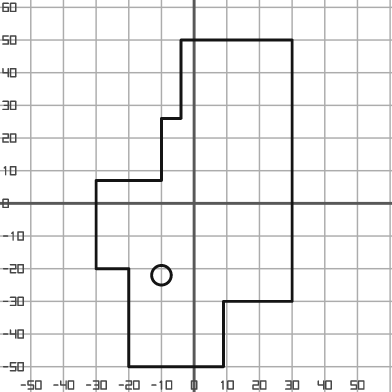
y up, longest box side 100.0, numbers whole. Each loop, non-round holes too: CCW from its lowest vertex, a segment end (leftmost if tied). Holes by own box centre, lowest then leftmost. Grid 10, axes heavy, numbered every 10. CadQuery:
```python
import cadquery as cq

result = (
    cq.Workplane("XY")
    .moveTo(-20.0, -50.0)
    .lineTo(9.0, -50.0)
    .lineTo(9.0, -30.0)
    .lineTo(30.0, -30.0)
    .lineTo(30.0, 50.0)
    .lineTo(-4.0, 50.0)
    .lineTo(-4.0, 26.0)
    .lineTo(-10.0, 26.0)
    .lineTo(-10.0, 7.0)
    .lineTo(-30.0, 7.0)
    .lineTo(-30.0, -20.0)
    .lineTo(-20.0, -20.0)
    .close()
    .moveTo(-10.0, -22.0)
    .circle(3.0)
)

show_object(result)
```